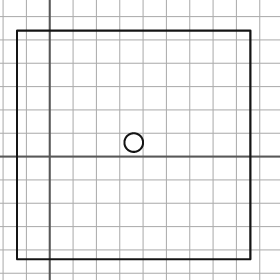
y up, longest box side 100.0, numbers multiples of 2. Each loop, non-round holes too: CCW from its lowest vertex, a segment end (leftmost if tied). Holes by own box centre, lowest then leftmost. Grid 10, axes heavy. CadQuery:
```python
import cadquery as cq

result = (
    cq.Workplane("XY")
    .moveTo(-14.0, -44.0)
    .lineTo(86.0, -44.0)
    .lineTo(86.0, 54.0)
    .lineTo(-14.0, 54.0)
    .close()
    .moveTo(36.0, 6.0)
    .circle(4.0)
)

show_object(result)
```